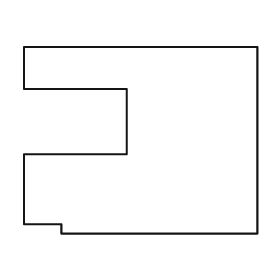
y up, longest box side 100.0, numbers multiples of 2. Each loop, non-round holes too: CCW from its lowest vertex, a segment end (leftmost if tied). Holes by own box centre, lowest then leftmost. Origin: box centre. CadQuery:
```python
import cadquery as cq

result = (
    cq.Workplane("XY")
    .moveTo(-34.0, -40.0)
    .lineTo(50.0, -40.0)
    .lineTo(50.0, 40.0)
    .lineTo(-50.0, 40.0)
    .lineTo(-50.0, 22.0)
    .lineTo(-6.0, 22.0)
    .lineTo(-6.0, -6.0)
    .lineTo(-50.0, -6.0)
    .lineTo(-50.0, -36.0)
    .lineTo(-34.0, -36.0)
    .close()
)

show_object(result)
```